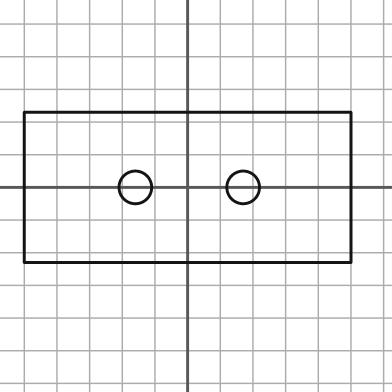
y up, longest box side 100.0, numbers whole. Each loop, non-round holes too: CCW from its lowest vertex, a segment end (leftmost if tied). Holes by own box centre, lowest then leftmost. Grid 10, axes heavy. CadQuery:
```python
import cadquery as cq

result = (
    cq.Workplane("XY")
    .moveTo(-50.0, -23.0)
    .lineTo(50.0, -23.0)
    .lineTo(50.0, 23.0)
    .lineTo(-50.0, 23.0)
    .close()
    .moveTo(-16.0, 0.0)
    .circle(5.0)
    .moveTo(17.0, 0.0)
    .circle(5.0)
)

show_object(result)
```